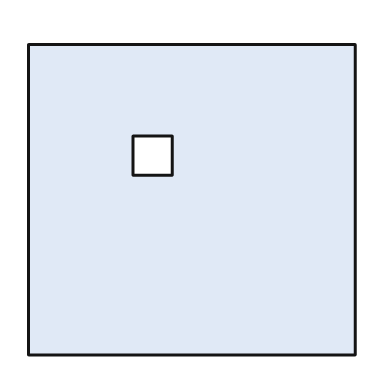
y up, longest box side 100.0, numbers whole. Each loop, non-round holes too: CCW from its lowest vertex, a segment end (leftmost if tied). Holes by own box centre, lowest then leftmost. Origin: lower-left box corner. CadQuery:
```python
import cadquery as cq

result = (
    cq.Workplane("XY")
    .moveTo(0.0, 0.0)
    .lineTo(100.0, 0.0)
    .lineTo(100.0, 95.0)
    .lineTo(0.0, 95.0)
    .close()
    .moveTo(32.0, 55.0)
    .lineTo(44.0, 55.0)
    .lineTo(44.0, 67.0)
    .lineTo(32.0, 67.0)
    .close()
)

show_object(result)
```